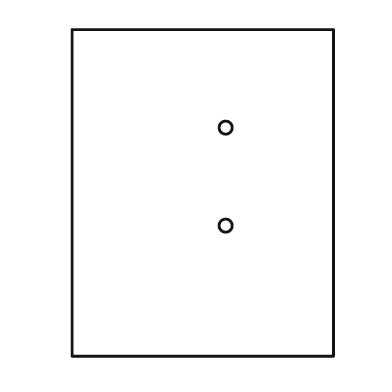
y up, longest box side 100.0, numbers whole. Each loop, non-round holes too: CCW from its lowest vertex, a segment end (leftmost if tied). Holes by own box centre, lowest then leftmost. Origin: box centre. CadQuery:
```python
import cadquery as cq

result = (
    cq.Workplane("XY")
    .moveTo(-40.0, -50.0)
    .lineTo(40.0, -50.0)
    .lineTo(40.0, 50.0)
    .lineTo(-40.0, 50.0)
    .close()
    .moveTo(7.0, -10.0)
    .circle(2.0)
    .moveTo(7.0, 20.0)
    .circle(2.0)
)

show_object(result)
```